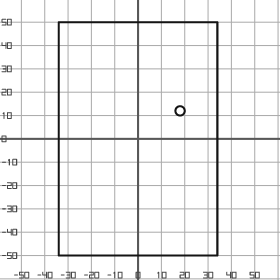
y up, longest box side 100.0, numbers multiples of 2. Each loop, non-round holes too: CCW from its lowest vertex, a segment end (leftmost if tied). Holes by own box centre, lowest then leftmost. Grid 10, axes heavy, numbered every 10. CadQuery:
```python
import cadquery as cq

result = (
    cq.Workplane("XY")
    .moveTo(-34.0, -50.0)
    .lineTo(34.0, -50.0)
    .lineTo(34.0, 50.0)
    .lineTo(-34.0, 50.0)
    .close()
    .moveTo(18.0, 12.0)
    .circle(2.0)
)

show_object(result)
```